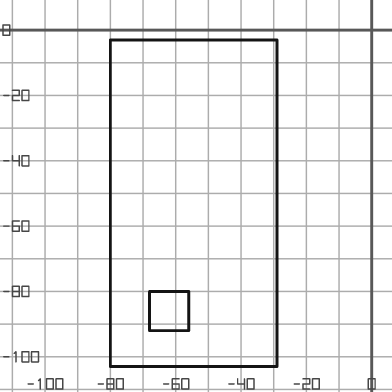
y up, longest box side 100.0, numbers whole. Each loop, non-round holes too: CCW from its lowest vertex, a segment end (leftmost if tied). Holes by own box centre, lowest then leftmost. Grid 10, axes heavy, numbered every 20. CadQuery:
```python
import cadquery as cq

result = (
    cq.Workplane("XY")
    .moveTo(-80.0, -103.0)
    .lineTo(-29.0, -103.0)
    .lineTo(-29.0, -3.0)
    .lineTo(-80.0, -3.0)
    .close()
    .moveTo(-68.0, -92.0)
    .lineTo(-56.0, -92.0)
    .lineTo(-56.0, -80.0)
    .lineTo(-68.0, -80.0)
    .close()
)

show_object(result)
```